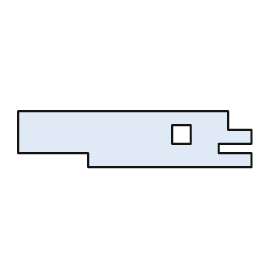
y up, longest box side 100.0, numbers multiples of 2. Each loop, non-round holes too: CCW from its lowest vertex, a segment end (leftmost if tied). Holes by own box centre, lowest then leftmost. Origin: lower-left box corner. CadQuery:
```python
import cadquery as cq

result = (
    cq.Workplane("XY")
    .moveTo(30.0, 0.0)
    .lineTo(100.0, 0.0)
    .lineTo(100.0, 6.0)
    .lineTo(86.0, 6.0)
    .lineTo(86.0, 10.0)
    .lineTo(100.0, 10.0)
    .lineTo(100.0, 16.0)
    .lineTo(90.0, 16.0)
    .lineTo(90.0, 24.0)
    .lineTo(0.0, 24.0)
    .lineTo(0.0, 6.0)
    .lineTo(30.0, 6.0)
    .close()
    .moveTo(66.0, 10.0)
    .lineTo(74.0, 10.0)
    .lineTo(74.0, 18.0)
    .lineTo(66.0, 18.0)
    .close()
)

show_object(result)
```